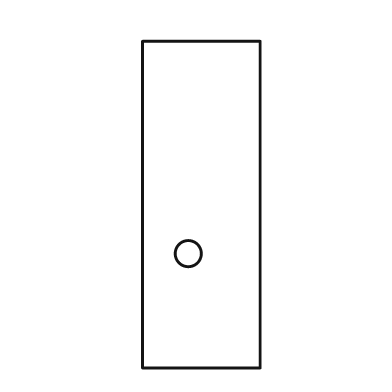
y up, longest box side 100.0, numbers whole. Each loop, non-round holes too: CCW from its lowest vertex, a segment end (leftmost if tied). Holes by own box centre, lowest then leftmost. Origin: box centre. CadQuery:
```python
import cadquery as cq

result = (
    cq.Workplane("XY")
    .moveTo(-18.0, -50.0)
    .lineTo(18.0, -50.0)
    .lineTo(18.0, 50.0)
    .lineTo(-18.0, 50.0)
    .close()
    .moveTo(-4.0, -15.0)
    .circle(4.0)
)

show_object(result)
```